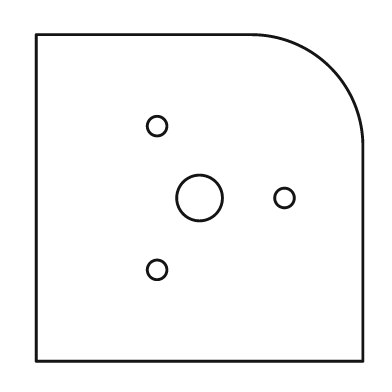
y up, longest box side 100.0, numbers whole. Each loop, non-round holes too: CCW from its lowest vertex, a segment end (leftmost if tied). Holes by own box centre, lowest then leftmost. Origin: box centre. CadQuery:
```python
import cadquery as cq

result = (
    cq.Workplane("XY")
    .moveTo(-50.0, -50.0)
    .lineTo(50.0, -50.0)
    .lineTo(50.0, 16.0)
    .threePointArc((40.0, 40.0), (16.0, 50.0))
    .lineTo(-50.0, 50.0)
    .close()
    .moveTo(-13.0, -22.0)
    .circle(3.0)
    .moveTo(0.0, 0.0)
    .circle(7.0)
    .moveTo(26.0, 0.0)
    .circle(3.0)
    .moveTo(-13.0, 22.0)
    .circle(3.0)
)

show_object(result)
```